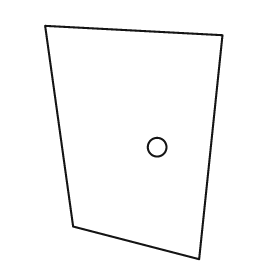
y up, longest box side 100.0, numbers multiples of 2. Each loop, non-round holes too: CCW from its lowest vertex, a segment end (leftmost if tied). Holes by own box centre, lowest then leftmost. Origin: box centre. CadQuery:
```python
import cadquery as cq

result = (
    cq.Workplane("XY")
    .moveTo(28.0, -50.0)
    .lineTo(38.0, 46.0)
    .lineTo(-38.0, 50.0)
    .lineTo(-26.0, -36.0)
    .close()
    .moveTo(10.0, -2.0)
    .circle(4.0)
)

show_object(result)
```